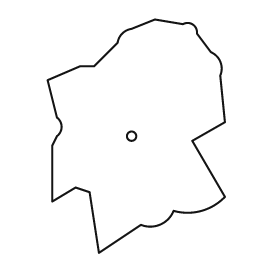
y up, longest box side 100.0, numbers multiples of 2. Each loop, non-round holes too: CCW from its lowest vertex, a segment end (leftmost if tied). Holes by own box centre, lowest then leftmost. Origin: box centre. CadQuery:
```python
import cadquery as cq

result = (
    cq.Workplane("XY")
    .moveTo(-16.0, -50.0)
    .lineTo(2.0, -38.0)
    .threePointArc((10.0, -38.0), (16.0, -32.0))
    .threePointArc((28.0, -32.0), (38.0, -26.0))
    .lineTo(24.0, -2.0)
    .lineTo(38.0, 6.0)
    .lineTo(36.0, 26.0)
    .threePointArc((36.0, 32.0), (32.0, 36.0))
    .lineTo(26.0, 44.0)
    .threePointArc((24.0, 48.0), (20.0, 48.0))
    .lineTo(8.0, 50.0)
    .lineTo(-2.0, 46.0)
    .threePointArc((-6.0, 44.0), (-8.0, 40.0))
    .lineTo(-18.0, 30.0)
    .lineTo(-24.0, 30.0)
    .lineTo(-38.0, 24.0)
    .lineTo(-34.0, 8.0)
    .threePointArc((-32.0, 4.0), (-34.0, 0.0))
    .lineTo(-36.0, -4.0)
    .lineTo(-36.0, -28.0)
    .lineTo(-26.0, -22.0)
    .lineTo(-20.0, -24.0)
    .close()
    .moveTo(-2.0, 0.0)
    .circle(2.0)
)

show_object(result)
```